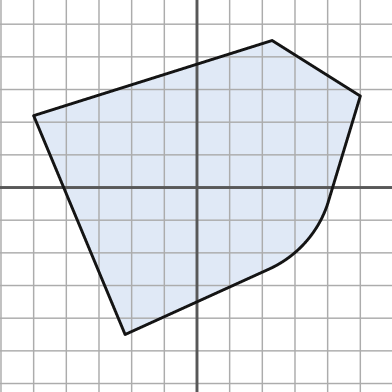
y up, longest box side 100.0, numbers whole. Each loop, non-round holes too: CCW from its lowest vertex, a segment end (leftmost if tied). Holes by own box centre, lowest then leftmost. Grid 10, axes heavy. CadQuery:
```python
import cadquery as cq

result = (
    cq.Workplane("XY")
    .moveTo(-22.0, -45.0)
    .lineTo(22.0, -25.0)
    .threePointArc((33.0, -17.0), (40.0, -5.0))
    .lineTo(50.0, 28.0)
    .lineTo(23.0, 45.0)
    .lineTo(-50.0, 22.0)
    .close()
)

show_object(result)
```